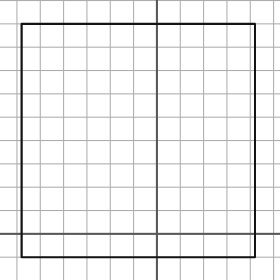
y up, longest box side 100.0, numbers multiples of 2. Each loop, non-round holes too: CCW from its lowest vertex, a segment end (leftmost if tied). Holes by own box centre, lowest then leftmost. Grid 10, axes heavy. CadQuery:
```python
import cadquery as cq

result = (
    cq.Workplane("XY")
    .moveTo(-58.0, -10.0)
    .lineTo(42.0, -10.0)
    .lineTo(42.0, 90.0)
    .lineTo(-58.0, 90.0)
    .close()
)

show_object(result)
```